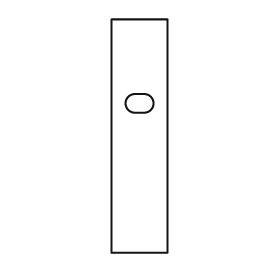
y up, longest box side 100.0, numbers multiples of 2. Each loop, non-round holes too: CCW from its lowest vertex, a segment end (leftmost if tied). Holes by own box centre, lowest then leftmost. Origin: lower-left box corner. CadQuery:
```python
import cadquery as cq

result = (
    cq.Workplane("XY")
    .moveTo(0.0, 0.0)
    .lineTo(24.0, 0.0)
    .lineTo(24.0, 100.0)
    .lineTo(0.0, 100.0)
    .close()
    .moveTo(10.0, 60.0)
    .lineTo(14.0, 60.0)
    .threePointArc((18.0, 64.0), (14.0, 68.0))
    .lineTo(10.0, 68.0)
    .threePointArc((6.0, 64.0), (10.0, 60.0))
    .close()
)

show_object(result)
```